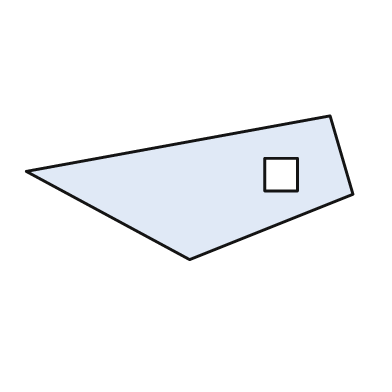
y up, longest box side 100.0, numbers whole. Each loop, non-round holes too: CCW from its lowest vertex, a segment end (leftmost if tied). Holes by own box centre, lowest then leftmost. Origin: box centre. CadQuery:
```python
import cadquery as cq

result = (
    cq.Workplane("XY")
    .moveTo(0.0, -22.0)
    .lineTo(50.0, -2.0)
    .lineTo(43.0, 22.0)
    .lineTo(-50.0, 5.0)
    .close()
    .moveTo(23.0, -1.0)
    .lineTo(33.0, -1.0)
    .lineTo(33.0, 9.0)
    .lineTo(23.0, 9.0)
    .close()
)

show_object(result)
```